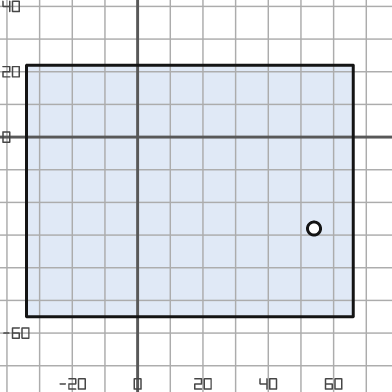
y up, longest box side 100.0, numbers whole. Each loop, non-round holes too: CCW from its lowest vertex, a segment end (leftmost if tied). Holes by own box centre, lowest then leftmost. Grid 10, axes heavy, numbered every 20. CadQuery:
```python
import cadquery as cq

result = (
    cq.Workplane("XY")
    .moveTo(-34.0, -55.0)
    .lineTo(66.0, -55.0)
    .lineTo(66.0, 22.0)
    .lineTo(-34.0, 22.0)
    .close()
    .moveTo(54.0, -28.0)
    .circle(2.0)
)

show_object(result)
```